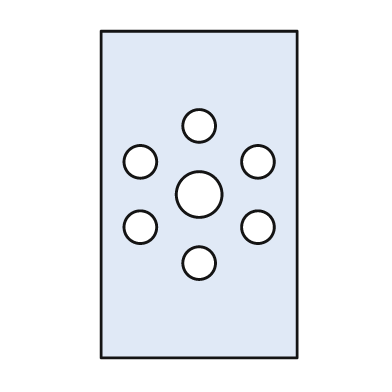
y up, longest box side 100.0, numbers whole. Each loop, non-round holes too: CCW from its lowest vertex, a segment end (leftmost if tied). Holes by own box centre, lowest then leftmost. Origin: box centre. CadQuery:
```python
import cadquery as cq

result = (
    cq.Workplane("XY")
    .moveTo(-30.0, -50.0)
    .lineTo(30.0, -50.0)
    .lineTo(30.0, 50.0)
    .lineTo(-30.0, 50.0)
    .close()
    .moveTo(0.0, -21.0)
    .circle(5.0)
    .moveTo(-18.0, -10.0)
    .circle(5.0)
    .moveTo(18.0, -10.0)
    .circle(5.0)
    .moveTo(0.0, 0.0)
    .circle(7.0)
    .moveTo(-18.0, 10.0)
    .circle(5.0)
    .moveTo(18.0, 10.0)
    .circle(5.0)
    .moveTo(0.0, 21.0)
    .circle(5.0)
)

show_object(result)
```